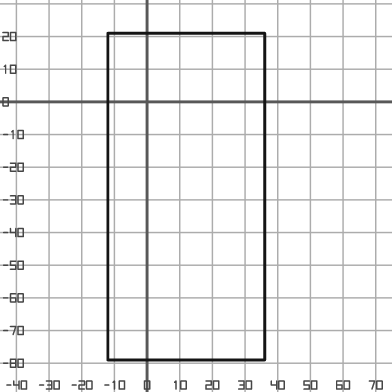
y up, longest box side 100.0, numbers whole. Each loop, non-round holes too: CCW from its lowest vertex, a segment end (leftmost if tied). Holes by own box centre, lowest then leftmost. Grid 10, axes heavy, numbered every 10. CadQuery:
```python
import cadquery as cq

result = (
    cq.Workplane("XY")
    .moveTo(-12.0, -79.0)
    .lineTo(36.0, -79.0)
    .lineTo(36.0, 21.0)
    .lineTo(-12.0, 21.0)
    .close()
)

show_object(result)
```